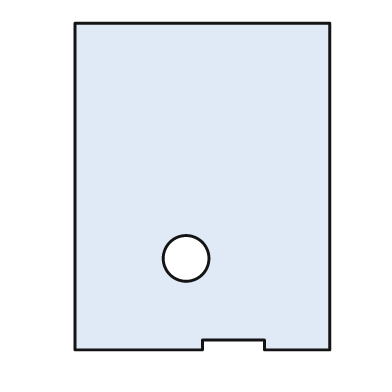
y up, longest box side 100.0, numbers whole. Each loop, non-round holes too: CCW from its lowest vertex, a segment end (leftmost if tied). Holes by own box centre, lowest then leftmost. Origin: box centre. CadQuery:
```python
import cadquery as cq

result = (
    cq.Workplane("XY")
    .moveTo(-39.0, -50.0)
    .lineTo(0.0, -50.0)
    .lineTo(0.0, -47.0)
    .lineTo(19.0, -47.0)
    .lineTo(19.0, -50.0)
    .lineTo(39.0, -50.0)
    .lineTo(39.0, 50.0)
    .lineTo(-39.0, 50.0)
    .close()
    .moveTo(-5.0, -22.0)
    .circle(7.0)
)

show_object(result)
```